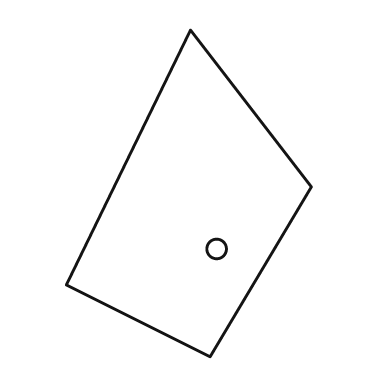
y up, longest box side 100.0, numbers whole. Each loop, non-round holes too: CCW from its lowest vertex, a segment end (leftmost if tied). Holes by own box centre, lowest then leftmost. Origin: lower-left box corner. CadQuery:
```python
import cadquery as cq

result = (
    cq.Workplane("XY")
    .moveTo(44.0, 0.0)
    .lineTo(75.0, 52.0)
    .lineTo(38.0, 100.0)
    .lineTo(0.0, 22.0)
    .close()
    .moveTo(46.0, 33.0)
    .circle(3.0)
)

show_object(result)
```